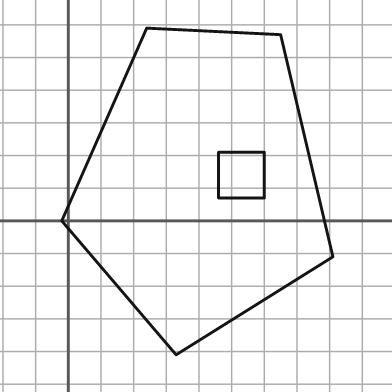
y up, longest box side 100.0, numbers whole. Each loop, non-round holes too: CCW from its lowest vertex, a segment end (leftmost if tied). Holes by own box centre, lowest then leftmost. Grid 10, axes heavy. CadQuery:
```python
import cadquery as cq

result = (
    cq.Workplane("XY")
    .moveTo(33.0, -41.0)
    .lineTo(81.0, -11.0)
    .lineTo(65.0, 57.0)
    .lineTo(24.0, 59.0)
    .lineTo(-2.0, 0.0)
    .close()
    .moveTo(46.0, 7.0)
    .lineTo(60.0, 7.0)
    .lineTo(60.0, 21.0)
    .lineTo(46.0, 21.0)
    .close()
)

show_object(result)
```